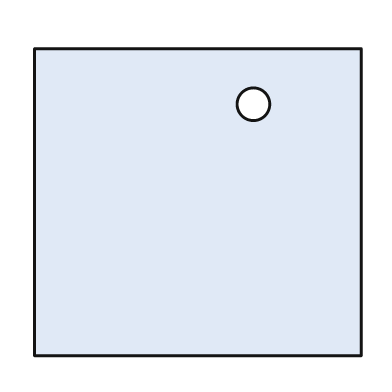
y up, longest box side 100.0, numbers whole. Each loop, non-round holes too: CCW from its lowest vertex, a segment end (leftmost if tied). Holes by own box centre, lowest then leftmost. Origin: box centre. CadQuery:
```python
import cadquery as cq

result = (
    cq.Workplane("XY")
    .moveTo(-50.0, -47.0)
    .lineTo(50.0, -47.0)
    .lineTo(50.0, 47.0)
    .lineTo(-50.0, 47.0)
    .close()
    .moveTo(17.0, 30.0)
    .circle(5.0)
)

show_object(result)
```